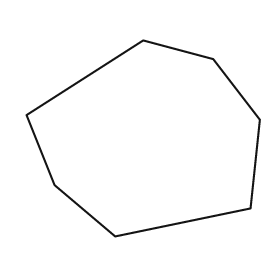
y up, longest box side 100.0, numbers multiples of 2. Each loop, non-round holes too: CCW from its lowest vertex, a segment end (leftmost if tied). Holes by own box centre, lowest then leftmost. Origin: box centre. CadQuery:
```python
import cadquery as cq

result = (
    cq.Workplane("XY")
    .moveTo(-12.0, -42.0)
    .lineTo(46.0, -30.0)
    .lineTo(50.0, 8.0)
    .lineTo(30.0, 34.0)
    .lineTo(0.0, 42.0)
    .lineTo(-50.0, 10.0)
    .lineTo(-38.0, -20.0)
    .close()
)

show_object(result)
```